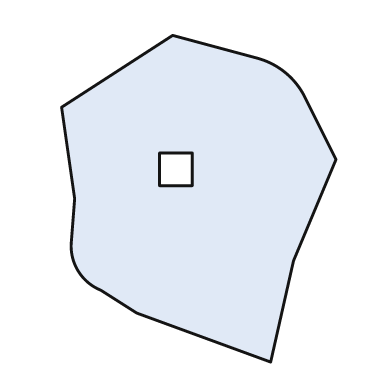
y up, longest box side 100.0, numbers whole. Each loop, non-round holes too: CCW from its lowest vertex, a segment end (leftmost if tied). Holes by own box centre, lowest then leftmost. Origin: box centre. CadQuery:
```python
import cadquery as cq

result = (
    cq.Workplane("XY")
    .moveTo(22.0, -50.0)
    .lineTo(29.0, -19.0)
    .lineTo(42.0, 12.0)
    .lineTo(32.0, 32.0)
    .threePointArc((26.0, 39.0), (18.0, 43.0))
    .lineTo(-8.0, 50.0)
    .lineTo(-42.0, 28.0)
    .lineTo(-38.0, 0.0)
    .lineTo(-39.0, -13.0)
    .threePointArc((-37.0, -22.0), (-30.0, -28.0))
    .lineTo(-19.0, -35.0)
    .close()
    .moveTo(-12.0, 4.0)
    .lineTo(-2.0, 4.0)
    .lineTo(-2.0, 14.0)
    .lineTo(-12.0, 14.0)
    .close()
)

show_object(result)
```